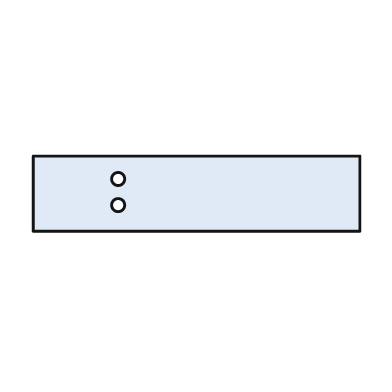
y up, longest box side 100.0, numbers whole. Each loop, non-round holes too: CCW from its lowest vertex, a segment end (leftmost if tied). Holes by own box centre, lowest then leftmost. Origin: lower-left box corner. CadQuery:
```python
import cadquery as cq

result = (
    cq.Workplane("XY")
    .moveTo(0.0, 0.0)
    .lineTo(100.0, 0.0)
    .lineTo(100.0, 23.0)
    .lineTo(0.0, 23.0)
    .close()
    .moveTo(26.0, 8.0)
    .circle(2.0)
    .moveTo(26.0, 16.0)
    .circle(2.0)
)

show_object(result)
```